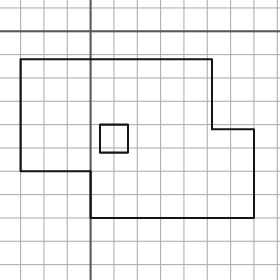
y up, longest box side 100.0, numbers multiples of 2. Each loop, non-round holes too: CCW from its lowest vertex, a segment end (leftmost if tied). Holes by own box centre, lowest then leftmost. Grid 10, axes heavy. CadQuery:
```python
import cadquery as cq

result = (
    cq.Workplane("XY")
    .moveTo(0.0, -80.0)
    .lineTo(70.0, -80.0)
    .lineTo(70.0, -42.0)
    .lineTo(52.0, -42.0)
    .lineTo(52.0, -12.0)
    .lineTo(-30.0, -12.0)
    .lineTo(-30.0, -60.0)
    .lineTo(0.0, -60.0)
    .close()
    .moveTo(4.0, -52.0)
    .lineTo(16.0, -52.0)
    .lineTo(16.0, -40.0)
    .lineTo(4.0, -40.0)
    .close()
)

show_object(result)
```